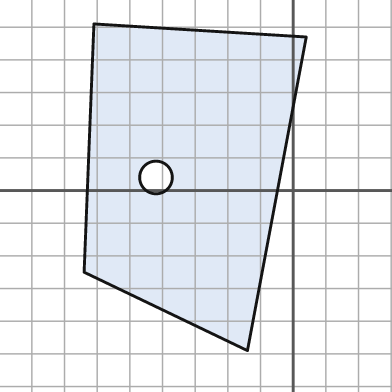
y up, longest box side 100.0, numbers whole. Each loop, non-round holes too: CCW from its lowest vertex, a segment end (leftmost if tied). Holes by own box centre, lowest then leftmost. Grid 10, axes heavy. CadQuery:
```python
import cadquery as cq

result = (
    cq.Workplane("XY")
    .moveTo(-14.0, -49.0)
    .lineTo(4.0, 47.0)
    .lineTo(-61.0, 51.0)
    .lineTo(-64.0, -25.0)
    .close()
    .moveTo(-42.0, 4.0)
    .circle(5.0)
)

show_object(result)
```